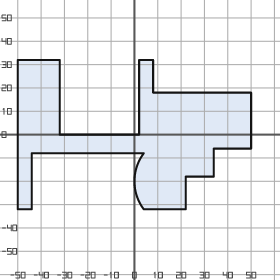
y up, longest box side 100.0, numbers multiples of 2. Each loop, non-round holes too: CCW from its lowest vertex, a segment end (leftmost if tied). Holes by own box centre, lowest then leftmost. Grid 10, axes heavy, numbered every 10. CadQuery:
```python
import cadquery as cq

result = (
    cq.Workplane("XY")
    .moveTo(-50.0, -32.0)
    .lineTo(-44.0, -32.0)
    .lineTo(-44.0, -8.0)
    .lineTo(4.0, -8.0)
    .threePointArc((0.0, -20.0), (4.0, -32.0))
    .lineTo(22.0, -32.0)
    .lineTo(22.0, -18.0)
    .lineTo(34.0, -18.0)
    .lineTo(34.0, -6.0)
    .lineTo(50.0, -6.0)
    .lineTo(50.0, 18.0)
    .lineTo(8.0, 18.0)
    .lineTo(8.0, 32.0)
    .lineTo(2.0, 32.0)
    .lineTo(2.0, 0.0)
    .lineTo(-32.0, 0.0)
    .lineTo(-32.0, 32.0)
    .lineTo(-50.0, 32.0)
    .close()
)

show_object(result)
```